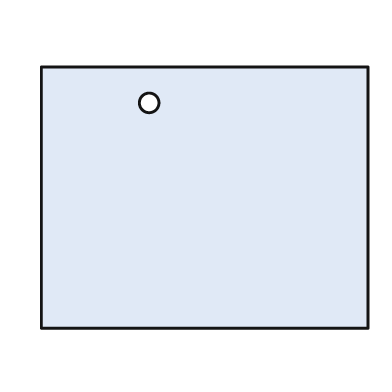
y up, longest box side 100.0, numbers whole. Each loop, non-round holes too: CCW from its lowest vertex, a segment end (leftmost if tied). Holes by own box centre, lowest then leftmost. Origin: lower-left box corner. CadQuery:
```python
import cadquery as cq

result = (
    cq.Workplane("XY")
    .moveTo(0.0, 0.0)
    .lineTo(100.0, 0.0)
    .lineTo(100.0, 80.0)
    .lineTo(0.0, 80.0)
    .close()
    .moveTo(33.0, 69.0)
    .circle(3.0)
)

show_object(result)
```